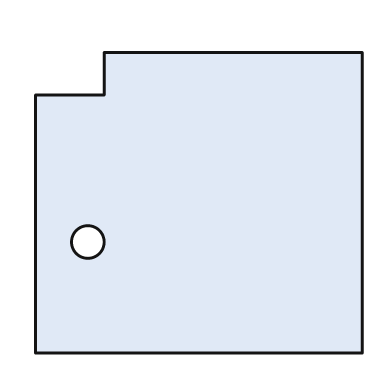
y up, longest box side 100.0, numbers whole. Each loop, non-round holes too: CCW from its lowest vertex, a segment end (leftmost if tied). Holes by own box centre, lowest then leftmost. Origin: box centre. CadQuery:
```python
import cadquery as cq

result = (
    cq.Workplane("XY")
    .moveTo(-50.0, -46.0)
    .lineTo(50.0, -46.0)
    .lineTo(50.0, 46.0)
    .lineTo(-29.0, 46.0)
    .lineTo(-29.0, 33.0)
    .lineTo(-50.0, 33.0)
    .close()
    .moveTo(-34.0, -12.0)
    .circle(5.0)
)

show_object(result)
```